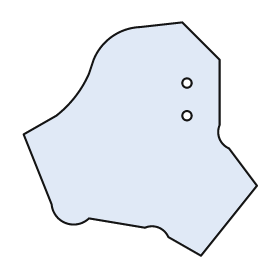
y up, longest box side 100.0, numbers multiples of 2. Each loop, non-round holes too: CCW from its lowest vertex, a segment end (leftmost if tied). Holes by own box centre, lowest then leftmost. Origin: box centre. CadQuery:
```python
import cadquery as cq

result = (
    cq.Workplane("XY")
    .moveTo(26.0, -50.0)
    .lineTo(50.0, -20.0)
    .lineTo(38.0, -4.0)
    .threePointArc((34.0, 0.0), (34.0, 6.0))
    .lineTo(34.0, 34.0)
    .lineTo(18.0, 50.0)
    .lineTo(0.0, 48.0)
    .threePointArc((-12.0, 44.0), (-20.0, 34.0))
    .lineTo(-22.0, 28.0)
    .threePointArc((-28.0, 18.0), (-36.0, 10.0))
    .lineTo(-50.0, 2.0)
    .lineTo(-38.0, -28.0)
    .threePointArc((-32.0, -36.0), (-22.0, -34.0))
    .lineTo(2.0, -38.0)
    .threePointArc((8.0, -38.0), (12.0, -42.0))
    .close()
    .moveTo(20.0, 10.0)
    .circle(2.0)
    .moveTo(20.0, 24.0)
    .circle(2.0)
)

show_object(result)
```